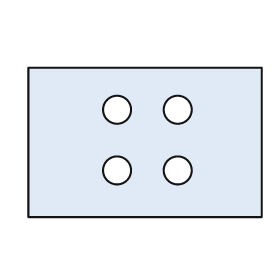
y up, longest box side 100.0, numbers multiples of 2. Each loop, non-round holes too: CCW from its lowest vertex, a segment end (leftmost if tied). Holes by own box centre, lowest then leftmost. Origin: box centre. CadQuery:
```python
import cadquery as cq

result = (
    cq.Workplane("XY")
    .moveTo(-50.0, -32.0)
    .lineTo(50.0, -32.0)
    .lineTo(50.0, 32.0)
    .lineTo(-50.0, 32.0)
    .close()
    .moveTo(-12.0, -12.0)
    .circle(6.0)
    .moveTo(14.0, -12.0)
    .circle(6.0)
    .moveTo(-12.0, 14.0)
    .circle(6.0)
    .moveTo(14.0, 14.0)
    .circle(6.0)
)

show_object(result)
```